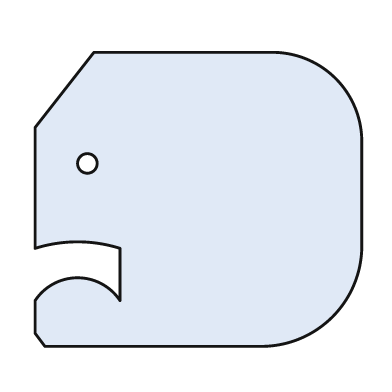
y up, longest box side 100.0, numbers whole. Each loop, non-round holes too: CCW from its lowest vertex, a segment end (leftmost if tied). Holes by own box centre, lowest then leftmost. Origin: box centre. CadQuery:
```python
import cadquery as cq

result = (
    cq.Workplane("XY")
    .moveTo(-47.0, -45.0)
    .lineTo(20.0, -45.0)
    .threePointArc((41.0, -36.0), (50.0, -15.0))
    .lineTo(50.0, 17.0)
    .threePointArc((42.0, 37.0), (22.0, 45.0))
    .lineTo(-32.0, 45.0)
    .lineTo(-50.0, 22.0)
    .lineTo(-50.0, -15.0)
    .threePointArc((-37.0, -13.0), (-24.0, -15.0))
    .lineTo(-24.0, -31.0)
    .threePointArc((-37.0, -24.0), (-50.0, -31.0))
    .lineTo(-50.0, -41.0)
    .close()
    .moveTo(-34.0, 11.0)
    .circle(3.0)
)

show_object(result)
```